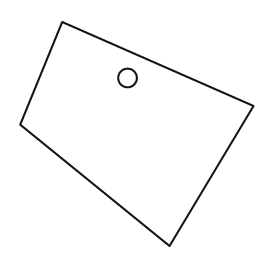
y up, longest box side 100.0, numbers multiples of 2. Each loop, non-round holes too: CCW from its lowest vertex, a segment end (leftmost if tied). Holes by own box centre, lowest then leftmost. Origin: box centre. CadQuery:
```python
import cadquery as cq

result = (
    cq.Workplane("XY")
    .moveTo(14.0, -48.0)
    .lineTo(50.0, 12.0)
    .lineTo(-32.0, 48.0)
    .lineTo(-50.0, 4.0)
    .close()
    .moveTo(-4.0, 24.0)
    .circle(4.0)
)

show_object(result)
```